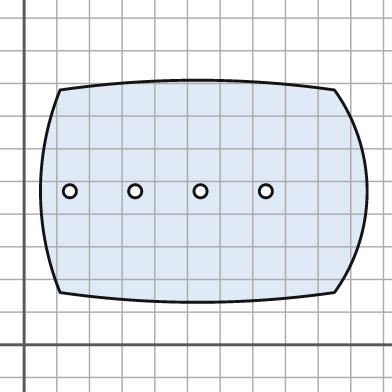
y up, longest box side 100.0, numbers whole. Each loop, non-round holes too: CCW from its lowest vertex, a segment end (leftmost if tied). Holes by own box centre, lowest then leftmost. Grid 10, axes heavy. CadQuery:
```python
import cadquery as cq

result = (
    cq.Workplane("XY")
    .moveTo(11.0, 16.0)
    .threePointArc((53.0, 13.0), (95.0, 16.0))
    .threePointArc((105.0, 47.0), (95.0, 78.0))
    .threePointArc((53.0, 81.0), (11.0, 78.0))
    .threePointArc((5.0, 47.0), (11.0, 16.0))
    .close()
    .moveTo(14.0, 47.0)
    .circle(2.0)
    .moveTo(34.0, 47.0)
    .circle(2.0)
    .moveTo(54.0, 47.0)
    .circle(2.0)
    .moveTo(74.0, 47.0)
    .circle(2.0)
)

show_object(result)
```